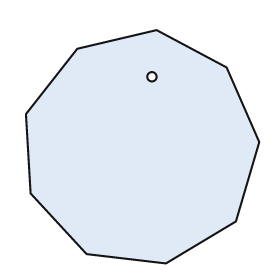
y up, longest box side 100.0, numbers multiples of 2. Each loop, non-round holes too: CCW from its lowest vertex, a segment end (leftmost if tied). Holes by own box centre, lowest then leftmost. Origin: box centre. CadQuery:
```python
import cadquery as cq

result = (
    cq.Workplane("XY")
    .moveTo(10.0, -50.0)
    .lineTo(40.0, -32.0)
    .lineTo(50.0, 2.0)
    .lineTo(36.0, 34.0)
    .lineTo(6.0, 50.0)
    .lineTo(-28.0, 42.0)
    .lineTo(-50.0, 14.0)
    .lineTo(-48.0, -20.0)
    .lineTo(-24.0, -46.0)
    .close()
    .moveTo(4.0, 30.0)
    .circle(2.0)
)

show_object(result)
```